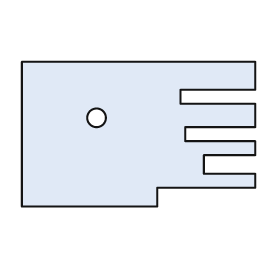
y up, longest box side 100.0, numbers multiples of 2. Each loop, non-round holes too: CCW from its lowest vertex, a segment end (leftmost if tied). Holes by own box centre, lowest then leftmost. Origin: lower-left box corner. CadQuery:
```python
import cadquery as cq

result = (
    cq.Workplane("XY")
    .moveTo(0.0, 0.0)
    .lineTo(58.0, 0.0)
    .lineTo(58.0, 8.0)
    .lineTo(100.0, 8.0)
    .lineTo(100.0, 14.0)
    .lineTo(78.0, 14.0)
    .lineTo(78.0, 22.0)
    .lineTo(100.0, 22.0)
    .lineTo(100.0, 28.0)
    .lineTo(70.0, 28.0)
    .lineTo(70.0, 34.0)
    .lineTo(100.0, 34.0)
    .lineTo(100.0, 44.0)
    .lineTo(68.0, 44.0)
    .lineTo(68.0, 50.0)
    .lineTo(100.0, 50.0)
    .lineTo(100.0, 62.0)
    .lineTo(0.0, 62.0)
    .close()
    .moveTo(32.0, 38.0)
    .circle(4.0)
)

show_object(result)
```